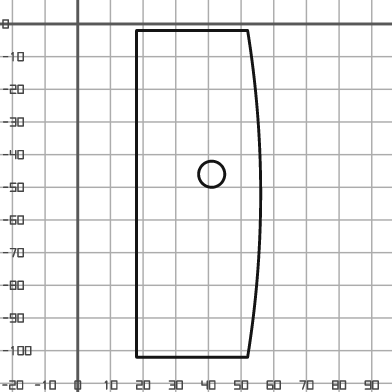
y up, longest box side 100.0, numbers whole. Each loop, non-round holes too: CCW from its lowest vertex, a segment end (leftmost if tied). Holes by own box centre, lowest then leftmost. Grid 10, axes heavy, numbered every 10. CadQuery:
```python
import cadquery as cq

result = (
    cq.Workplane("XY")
    .moveTo(18.0, -102.0)
    .lineTo(52.0, -102.0)
    .threePointArc((56.0, -52.0), (52.0, -2.0))
    .lineTo(18.0, -2.0)
    .close()
    .moveTo(41.0, -46.0)
    .circle(4.0)
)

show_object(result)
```